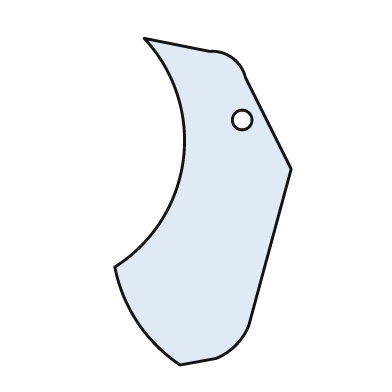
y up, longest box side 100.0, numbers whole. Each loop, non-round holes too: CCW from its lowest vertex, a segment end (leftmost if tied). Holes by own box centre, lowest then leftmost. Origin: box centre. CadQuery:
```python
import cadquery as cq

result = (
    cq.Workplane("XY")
    .moveTo(-7.0, -50.0)
    .lineTo(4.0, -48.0)
    .threePointArc((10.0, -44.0), (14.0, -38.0))
    .lineTo(27.0, 10.0)
    .lineTo(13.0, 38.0)
    .threePointArc((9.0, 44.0), (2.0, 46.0))
    .lineTo(-18.0, 50.0)
    .threePointArc((-6.0, 13.0), (-27.0, -20.0))
    .threePointArc((-20.0, -37.0), (-7.0, -50.0))
    .close()
    .moveTo(12.0, 25.0)
    .circle(3.0)
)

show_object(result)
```